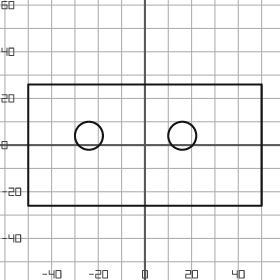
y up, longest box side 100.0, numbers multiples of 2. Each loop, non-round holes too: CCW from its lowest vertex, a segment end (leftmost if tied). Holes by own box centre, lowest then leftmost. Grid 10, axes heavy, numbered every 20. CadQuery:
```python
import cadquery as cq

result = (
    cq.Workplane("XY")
    .moveTo(-50.0, -26.0)
    .lineTo(50.0, -26.0)
    .lineTo(50.0, 26.0)
    .lineTo(-50.0, 26.0)
    .close()
    .moveTo(-24.0, 4.0)
    .circle(6.0)
    .moveTo(16.0, 4.0)
    .circle(6.0)
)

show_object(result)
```